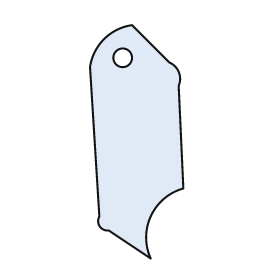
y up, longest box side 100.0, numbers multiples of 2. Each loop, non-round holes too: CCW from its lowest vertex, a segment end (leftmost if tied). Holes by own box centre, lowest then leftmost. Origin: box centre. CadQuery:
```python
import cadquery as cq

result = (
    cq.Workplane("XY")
    .moveTo(6.0, -50.0)
    .threePointArc((6.0, -32.0), (20.0, -20.0))
    .lineTo(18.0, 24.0)
    .threePointArc((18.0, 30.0), (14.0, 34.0))
    .lineTo(-2.0, 50.0)
    .threePointArc((-14.0, 44.0), (-20.0, 32.0))
    .lineTo(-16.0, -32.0)
    .threePointArc((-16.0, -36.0), (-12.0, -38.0))
    .close()
    .moveTo(-6.0, 36.0)
    .circle(4.0)
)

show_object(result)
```